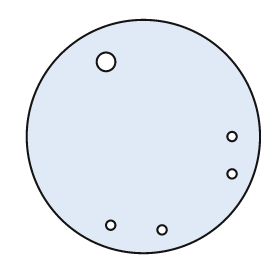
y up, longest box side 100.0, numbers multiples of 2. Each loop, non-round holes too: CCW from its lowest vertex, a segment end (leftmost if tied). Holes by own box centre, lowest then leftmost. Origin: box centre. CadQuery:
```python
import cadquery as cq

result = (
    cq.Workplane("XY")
    .moveTo(0.0, 0.0)
    .circle(50.0)
    .moveTo(8.0, -40.0)
    .circle(2.0)
    .moveTo(-14.0, -38.0)
    .circle(2.0)
    .moveTo(38.0, -16.0)
    .circle(2.0)
    .moveTo(38.0, 0.0)
    .circle(2.0)
    .moveTo(-16.0, 32.0)
    .circle(4.0)
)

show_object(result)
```